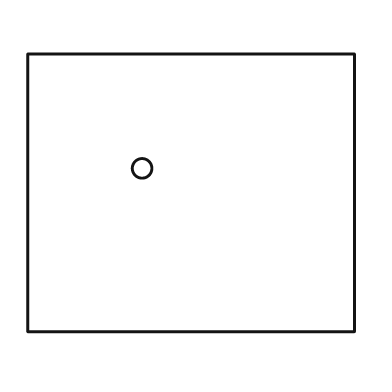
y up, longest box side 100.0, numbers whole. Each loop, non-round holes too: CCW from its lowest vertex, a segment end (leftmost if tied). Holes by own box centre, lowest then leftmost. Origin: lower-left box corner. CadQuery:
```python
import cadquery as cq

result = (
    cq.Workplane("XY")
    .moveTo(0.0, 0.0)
    .lineTo(100.0, 0.0)
    .lineTo(100.0, 85.0)
    .lineTo(0.0, 85.0)
    .close()
    .moveTo(35.0, 50.0)
    .circle(3.0)
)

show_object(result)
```